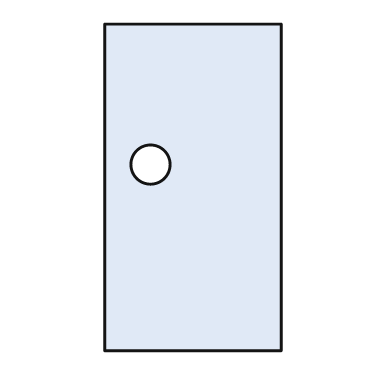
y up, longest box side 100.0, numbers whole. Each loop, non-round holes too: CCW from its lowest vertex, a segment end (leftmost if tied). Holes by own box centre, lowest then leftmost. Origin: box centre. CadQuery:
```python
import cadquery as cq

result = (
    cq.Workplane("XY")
    .moveTo(-27.0, -50.0)
    .lineTo(27.0, -50.0)
    .lineTo(27.0, 50.0)
    .lineTo(-27.0, 50.0)
    .close()
    .moveTo(-13.0, 7.0)
    .circle(6.0)
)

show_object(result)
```